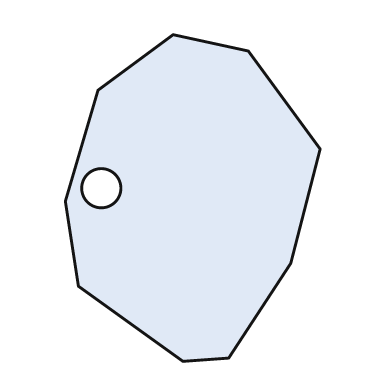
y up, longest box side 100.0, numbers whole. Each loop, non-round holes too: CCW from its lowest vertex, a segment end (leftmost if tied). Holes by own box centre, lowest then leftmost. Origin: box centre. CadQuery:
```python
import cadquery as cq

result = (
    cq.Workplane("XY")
    .moveTo(-3.0, -50.0)
    .lineTo(11.0, -49.0)
    .lineTo(30.0, -20.0)
    .lineTo(39.0, 15.0)
    .lineTo(17.0, 45.0)
    .lineTo(-6.0, 50.0)
    .lineTo(-29.0, 33.0)
    .lineTo(-39.0, -1.0)
    .lineTo(-35.0, -27.0)
    .close()
    .moveTo(-28.0, 3.0)
    .circle(6.0)
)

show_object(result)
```